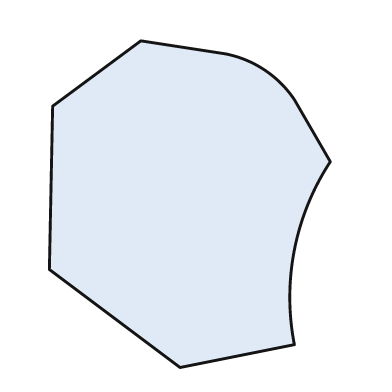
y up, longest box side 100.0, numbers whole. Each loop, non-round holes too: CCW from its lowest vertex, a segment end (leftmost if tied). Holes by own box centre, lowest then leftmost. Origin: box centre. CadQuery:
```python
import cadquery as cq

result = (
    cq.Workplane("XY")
    .moveTo(-3.0, -50.0)
    .lineTo(32.0, -43.0)
    .threePointArc((32.0, -14.0), (43.0, 13.0))
    .lineTo(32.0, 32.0)
    .threePointArc((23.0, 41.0), (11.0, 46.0))
    .lineTo(-15.0, 50.0)
    .lineTo(-42.0, 30.0)
    .lineTo(-43.0, -20.0)
    .close()
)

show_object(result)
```